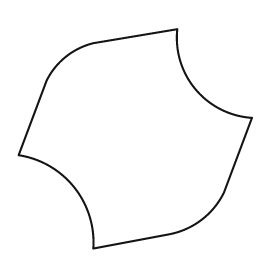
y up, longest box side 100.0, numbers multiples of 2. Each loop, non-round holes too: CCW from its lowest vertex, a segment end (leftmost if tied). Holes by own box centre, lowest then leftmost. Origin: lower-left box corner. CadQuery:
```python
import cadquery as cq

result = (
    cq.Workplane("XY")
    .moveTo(32.0, 0.0)
    .lineTo(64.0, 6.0)
    .threePointArc((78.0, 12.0), (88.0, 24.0))
    .lineTo(100.0, 56.0)
    .threePointArc((76.0, 68.0), (68.0, 94.0))
    .lineTo(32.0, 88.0)
    .threePointArc((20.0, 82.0), (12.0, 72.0))
    .lineTo(0.0, 40.0)
    .threePointArc((24.0, 26.0), (32.0, 0.0))
    .close()
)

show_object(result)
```